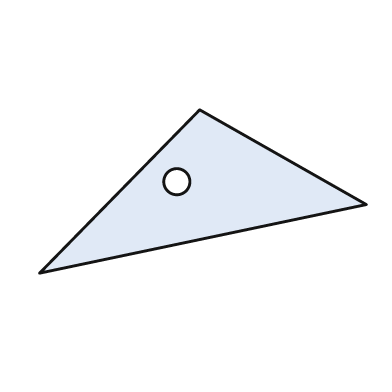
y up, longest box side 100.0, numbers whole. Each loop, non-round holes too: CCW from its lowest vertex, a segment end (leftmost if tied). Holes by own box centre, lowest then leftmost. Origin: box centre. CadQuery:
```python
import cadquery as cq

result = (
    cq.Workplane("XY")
    .moveTo(-50.0, -25.0)
    .lineTo(50.0, -4.0)
    .lineTo(-1.0, 25.0)
    .close()
    .moveTo(-8.0, 3.0)
    .circle(4.0)
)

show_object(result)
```